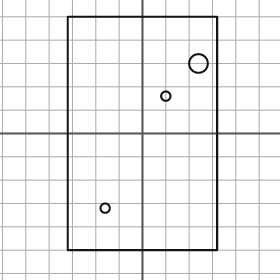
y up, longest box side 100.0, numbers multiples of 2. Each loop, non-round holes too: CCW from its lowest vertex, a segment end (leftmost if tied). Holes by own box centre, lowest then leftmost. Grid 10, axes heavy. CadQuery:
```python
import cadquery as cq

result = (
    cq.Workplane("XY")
    .moveTo(-32.0, -50.0)
    .lineTo(32.0, -50.0)
    .lineTo(32.0, 50.0)
    .lineTo(-32.0, 50.0)
    .close()
    .moveTo(-16.0, -32.0)
    .circle(2.0)
    .moveTo(10.0, 16.0)
    .circle(2.0)
    .moveTo(24.0, 30.0)
    .circle(4.0)
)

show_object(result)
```